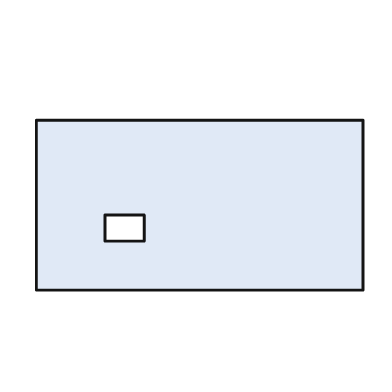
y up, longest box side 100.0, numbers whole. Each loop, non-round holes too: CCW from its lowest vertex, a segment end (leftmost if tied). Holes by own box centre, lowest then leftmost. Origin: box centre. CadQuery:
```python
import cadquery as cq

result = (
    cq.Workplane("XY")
    .moveTo(-50.0, -26.0)
    .lineTo(50.0, -26.0)
    .lineTo(50.0, 26.0)
    .lineTo(-50.0, 26.0)
    .close()
    .moveTo(-29.0, -11.0)
    .lineTo(-17.0, -11.0)
    .lineTo(-17.0, -3.0)
    .lineTo(-29.0, -3.0)
    .close()
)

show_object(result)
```